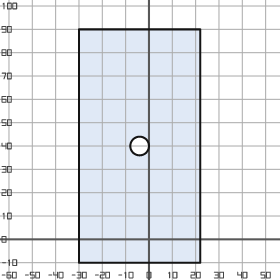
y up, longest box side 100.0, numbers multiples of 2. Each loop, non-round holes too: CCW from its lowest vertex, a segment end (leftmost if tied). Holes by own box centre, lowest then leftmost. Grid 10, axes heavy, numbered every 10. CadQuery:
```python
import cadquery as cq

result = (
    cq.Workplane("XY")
    .moveTo(-30.0, -10.0)
    .lineTo(22.0, -10.0)
    .lineTo(22.0, 90.0)
    .lineTo(-30.0, 90.0)
    .close()
    .moveTo(-4.0, 40.0)
    .circle(4.0)
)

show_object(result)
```